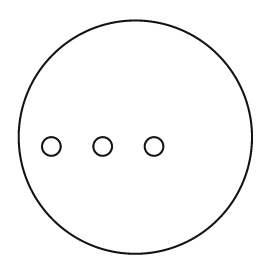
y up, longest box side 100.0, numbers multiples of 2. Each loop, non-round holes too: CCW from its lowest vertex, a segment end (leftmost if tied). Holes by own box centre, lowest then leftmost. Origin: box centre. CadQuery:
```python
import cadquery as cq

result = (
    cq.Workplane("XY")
    .moveTo(0.0, 0.0)
    .circle(50.0)
    .moveTo(-36.0, -4.0)
    .circle(4.0)
    .moveTo(-14.0, -4.0)
    .circle(4.0)
    .moveTo(8.0, -4.0)
    .circle(4.0)
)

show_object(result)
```